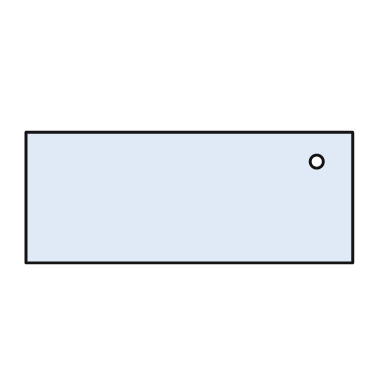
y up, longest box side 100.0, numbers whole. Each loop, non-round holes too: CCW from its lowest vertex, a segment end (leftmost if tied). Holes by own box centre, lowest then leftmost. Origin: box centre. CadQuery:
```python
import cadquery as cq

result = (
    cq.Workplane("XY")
    .moveTo(-50.0, -20.0)
    .lineTo(50.0, -20.0)
    .lineTo(50.0, 20.0)
    .lineTo(-50.0, 20.0)
    .close()
    .moveTo(39.0, 11.0)
    .circle(2.0)
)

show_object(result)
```